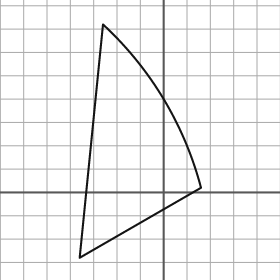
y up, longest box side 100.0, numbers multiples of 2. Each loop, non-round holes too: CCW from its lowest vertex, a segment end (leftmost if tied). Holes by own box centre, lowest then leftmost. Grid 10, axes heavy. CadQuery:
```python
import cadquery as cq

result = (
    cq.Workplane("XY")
    .moveTo(-36.0, -28.0)
    .lineTo(16.0, 2.0)
    .threePointArc((0.0, 40.0), (-26.0, 72.0))
    .close()
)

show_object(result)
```